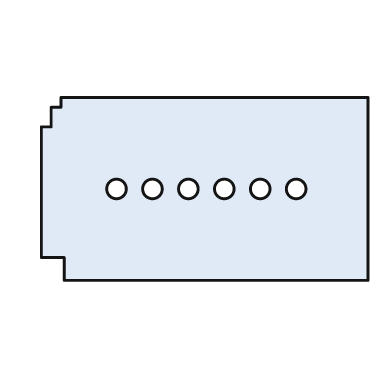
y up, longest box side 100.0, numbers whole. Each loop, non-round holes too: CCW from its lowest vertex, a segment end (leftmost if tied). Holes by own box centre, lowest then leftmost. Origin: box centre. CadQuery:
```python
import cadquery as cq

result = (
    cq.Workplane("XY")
    .moveTo(-43.0, -28.0)
    .lineTo(50.0, -28.0)
    .lineTo(50.0, 28.0)
    .lineTo(-44.0, 28.0)
    .lineTo(-44.0, 25.0)
    .lineTo(-47.0, 25.0)
    .lineTo(-47.0, 19.0)
    .lineTo(-50.0, 19.0)
    .lineTo(-50.0, -21.0)
    .lineTo(-43.0, -21.0)
    .close()
    .moveTo(-27.0, 0.0)
    .circle(3.0)
    .moveTo(-16.0, 0.0)
    .circle(3.0)
    .moveTo(-5.0, 0.0)
    .circle(3.0)
    .moveTo(6.0, 0.0)
    .circle(3.0)
    .moveTo(17.0, 0.0)
    .circle(3.0)
    .moveTo(28.0, 0.0)
    .circle(3.0)
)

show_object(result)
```